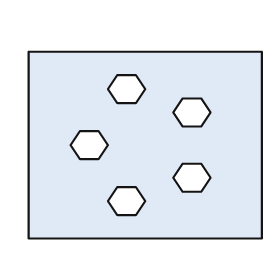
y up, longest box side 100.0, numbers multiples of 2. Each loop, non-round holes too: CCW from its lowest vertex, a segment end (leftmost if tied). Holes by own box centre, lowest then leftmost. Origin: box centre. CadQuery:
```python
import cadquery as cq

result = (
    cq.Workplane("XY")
    .moveTo(-50.0, -40.0)
    .lineTo(50.0, -40.0)
    .lineTo(50.0, 40.0)
    .lineTo(-50.0, 40.0)
    .close()
    .moveTo(-12.0, -30.0)
    .lineTo(-4.0, -30.0)
    .lineTo(0.0, -24.0)
    .lineTo(-4.0, -18.0)
    .lineTo(-12.0, -18.0)
    .lineTo(-16.0, -24.0)
    .close()
    .moveTo(16.0, -20.0)
    .lineTo(24.0, -20.0)
    .lineTo(28.0, -14.0)
    .lineTo(24.0, -8.0)
    .lineTo(16.0, -8.0)
    .lineTo(12.0, -14.0)
    .close()
    .moveTo(-28.0, -6.0)
    .lineTo(-20.0, -6.0)
    .lineTo(-16.0, 0.0)
    .lineTo(-20.0, 6.0)
    .lineTo(-28.0, 6.0)
    .lineTo(-32.0, 0.0)
    .close()
    .moveTo(16.0, 8.0)
    .lineTo(24.0, 8.0)
    .lineTo(28.0, 14.0)
    .lineTo(24.0, 20.0)
    .lineTo(16.0, 20.0)
    .lineTo(12.0, 14.0)
    .close()
    .moveTo(-12.0, 18.0)
    .lineTo(-4.0, 18.0)
    .lineTo(0.0, 24.0)
    .lineTo(-4.0, 30.0)
    .lineTo(-12.0, 30.0)
    .lineTo(-16.0, 24.0)
    .close()
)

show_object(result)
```